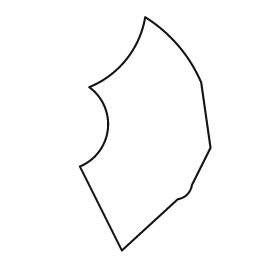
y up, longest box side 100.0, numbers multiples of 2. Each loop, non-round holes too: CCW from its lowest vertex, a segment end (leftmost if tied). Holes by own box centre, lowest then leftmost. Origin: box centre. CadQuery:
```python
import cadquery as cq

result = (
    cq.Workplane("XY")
    .moveTo(-10.0, -50.0)
    .lineTo(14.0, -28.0)
    .threePointArc((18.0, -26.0), (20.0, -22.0))
    .lineTo(28.0, -6.0)
    .lineTo(24.0, 22.0)
    .threePointArc((14.0, 38.0), (0.0, 50.0))
    .threePointArc((-8.0, 32.0), (-24.0, 20.0))
    .threePointArc((-16.0, 2.0), (-28.0, -14.0))
    .close()
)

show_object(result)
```